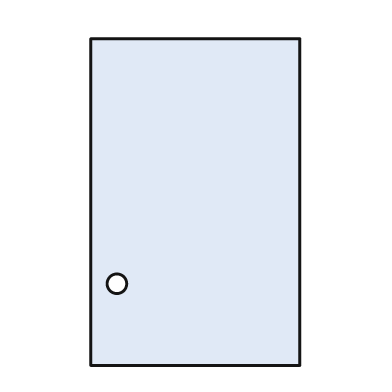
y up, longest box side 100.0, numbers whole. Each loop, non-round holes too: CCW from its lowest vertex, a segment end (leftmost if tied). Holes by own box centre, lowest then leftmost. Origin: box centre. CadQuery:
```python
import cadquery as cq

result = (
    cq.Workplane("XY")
    .moveTo(-32.0, -50.0)
    .lineTo(32.0, -50.0)
    .lineTo(32.0, 50.0)
    .lineTo(-32.0, 50.0)
    .close()
    .moveTo(-24.0, -25.0)
    .circle(3.0)
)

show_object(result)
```